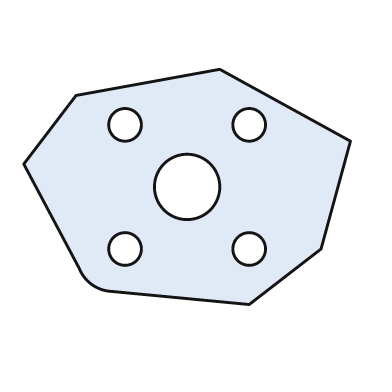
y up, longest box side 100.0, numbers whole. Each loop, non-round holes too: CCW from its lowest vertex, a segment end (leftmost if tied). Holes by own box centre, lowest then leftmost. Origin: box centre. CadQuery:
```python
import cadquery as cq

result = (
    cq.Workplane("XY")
    .moveTo(19.0, -36.0)
    .lineTo(41.0, -19.0)
    .lineTo(50.0, 14.0)
    .lineTo(10.0, 36.0)
    .lineTo(-34.0, 28.0)
    .lineTo(-50.0, 7.0)
    .lineTo(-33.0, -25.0)
    .threePointArc((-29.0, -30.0), (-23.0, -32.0))
    .close()
    .moveTo(-19.0, -19.0)
    .circle(5.0)
    .moveTo(19.0, -19.0)
    .circle(5.0)
    .moveTo(0.0, 0.0)
    .circle(10.0)
    .moveTo(-19.0, 19.0)
    .circle(5.0)
    .moveTo(19.0, 19.0)
    .circle(5.0)
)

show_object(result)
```